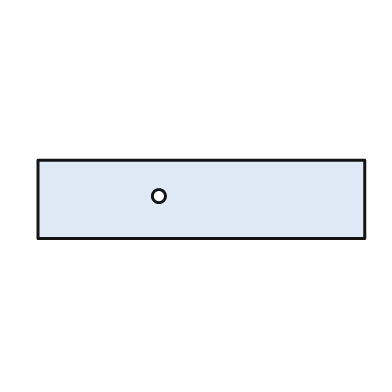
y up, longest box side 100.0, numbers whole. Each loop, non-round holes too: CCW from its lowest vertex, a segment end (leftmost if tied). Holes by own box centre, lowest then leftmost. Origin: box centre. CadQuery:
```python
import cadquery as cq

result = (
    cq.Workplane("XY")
    .moveTo(-50.0, -12.0)
    .lineTo(50.0, -12.0)
    .lineTo(50.0, 12.0)
    .lineTo(-50.0, 12.0)
    .close()
    .moveTo(-13.0, 1.0)
    .circle(2.0)
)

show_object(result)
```